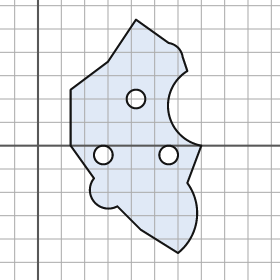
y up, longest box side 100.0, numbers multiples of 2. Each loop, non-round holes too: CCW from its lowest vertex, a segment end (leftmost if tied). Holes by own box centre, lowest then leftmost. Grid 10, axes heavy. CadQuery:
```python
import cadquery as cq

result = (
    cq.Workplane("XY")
    .moveTo(60.0, -46.0)
    .threePointArc((68.0, -32.0), (64.0, -16.0))
    .lineTo(70.0, 0.0)
    .threePointArc((56.0, 14.0), (64.0, 32.0))
    .lineTo(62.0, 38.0)
    .threePointArc((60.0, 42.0), (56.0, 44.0))
    .lineTo(42.0, 54.0)
    .lineTo(30.0, 36.0)
    .lineTo(14.0, 24.0)
    .lineTo(14.0, 0.0)
    .lineTo(24.0, -14.0)
    .threePointArc((24.0, -24.0), (34.0, -26.0))
    .lineTo(44.0, -36.0)
    .close()
    .moveTo(28.0, -4.0)
    .circle(4.0)
    .moveTo(56.0, -4.0)
    .circle(4.0)
    .moveTo(42.0, 20.0)
    .circle(4.0)
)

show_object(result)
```